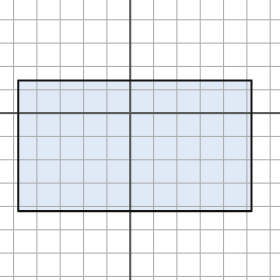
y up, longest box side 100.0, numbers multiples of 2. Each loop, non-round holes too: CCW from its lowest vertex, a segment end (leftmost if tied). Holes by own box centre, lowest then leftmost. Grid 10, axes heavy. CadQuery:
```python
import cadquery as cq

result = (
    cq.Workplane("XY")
    .moveTo(-48.0, -42.0)
    .lineTo(52.0, -42.0)
    .lineTo(52.0, 14.0)
    .lineTo(-48.0, 14.0)
    .close()
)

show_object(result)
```